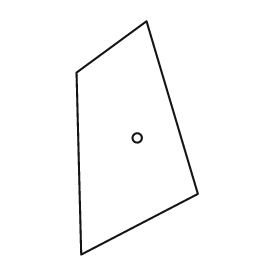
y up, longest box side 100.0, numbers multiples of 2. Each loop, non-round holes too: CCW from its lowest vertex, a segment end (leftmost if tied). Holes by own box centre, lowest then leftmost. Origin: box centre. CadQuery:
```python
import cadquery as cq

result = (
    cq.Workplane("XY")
    .moveTo(-24.0, -50.0)
    .lineTo(26.0, -24.0)
    .lineTo(4.0, 50.0)
    .lineTo(-26.0, 28.0)
    .close()
    .moveTo(0.0, 0.0)
    .circle(2.0)
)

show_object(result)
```